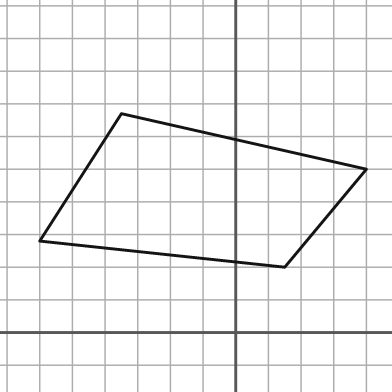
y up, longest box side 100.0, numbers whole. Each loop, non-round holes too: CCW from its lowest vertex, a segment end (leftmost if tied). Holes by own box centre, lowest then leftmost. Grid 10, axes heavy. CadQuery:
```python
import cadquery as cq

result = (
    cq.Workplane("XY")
    .moveTo(15.0, 20.0)
    .lineTo(40.0, 50.0)
    .lineTo(-35.0, 67.0)
    .lineTo(-60.0, 28.0)
    .close()
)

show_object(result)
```